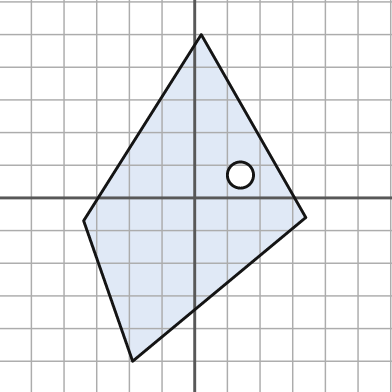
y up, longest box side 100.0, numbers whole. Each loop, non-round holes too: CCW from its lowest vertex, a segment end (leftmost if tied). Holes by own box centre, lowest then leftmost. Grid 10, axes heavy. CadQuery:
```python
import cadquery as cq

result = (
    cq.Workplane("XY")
    .moveTo(-19.0, -50.0)
    .lineTo(34.0, -6.0)
    .lineTo(2.0, 50.0)
    .lineTo(-34.0, -7.0)
    .close()
    .moveTo(14.0, 7.0)
    .circle(4.0)
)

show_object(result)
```